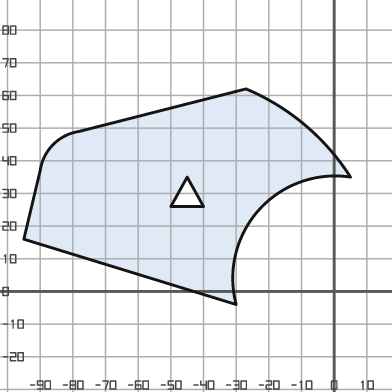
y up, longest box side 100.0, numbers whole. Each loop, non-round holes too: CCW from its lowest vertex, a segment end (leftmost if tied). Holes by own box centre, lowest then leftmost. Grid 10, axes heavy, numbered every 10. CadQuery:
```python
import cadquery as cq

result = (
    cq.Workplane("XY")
    .moveTo(-30.0, -4.0)
    .threePointArc((-23.0, 25.0), (5.0, 35.0))
    .threePointArc((-9.0, 51.0), (-27.0, 62.0))
    .lineTo(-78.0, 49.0)
    .threePointArc((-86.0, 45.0), (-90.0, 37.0))
    .lineTo(-95.0, 16.0)
    .close()
    .moveTo(-50.0, 26.0)
    .lineTo(-40.0, 26.0)
    .lineTo(-45.0, 35.0)
    .close()
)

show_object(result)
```